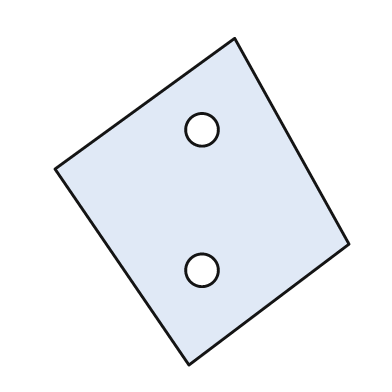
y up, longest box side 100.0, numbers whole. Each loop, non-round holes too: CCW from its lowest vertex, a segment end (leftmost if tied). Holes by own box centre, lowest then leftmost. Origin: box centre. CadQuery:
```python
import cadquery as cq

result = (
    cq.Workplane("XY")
    .moveTo(-4.0, -50.0)
    .lineTo(45.0, -13.0)
    .lineTo(10.0, 50.0)
    .lineTo(-45.0, 10.0)
    .close()
    .moveTo(0.0, -21.0)
    .circle(5.0)
    .moveTo(0.0, 22.0)
    .circle(5.0)
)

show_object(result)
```